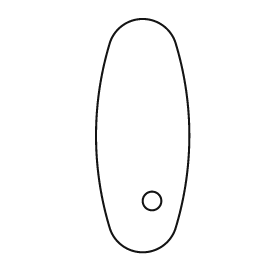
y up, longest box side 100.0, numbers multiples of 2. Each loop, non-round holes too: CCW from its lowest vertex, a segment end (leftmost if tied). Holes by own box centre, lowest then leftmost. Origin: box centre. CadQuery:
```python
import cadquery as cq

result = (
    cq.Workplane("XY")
    .moveTo(-14.0, -40.0)
    .threePointArc((0.0, -50.0), (14.0, -40.0))
    .threePointArc((20.0, 0.0), (14.0, 40.0))
    .threePointArc((0.0, 50.0), (-14.0, 40.0))
    .threePointArc((-20.0, 0.0), (-14.0, -40.0))
    .close()
    .moveTo(4.0, -28.0)
    .circle(4.0)
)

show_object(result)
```